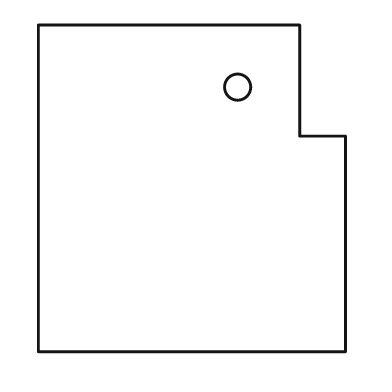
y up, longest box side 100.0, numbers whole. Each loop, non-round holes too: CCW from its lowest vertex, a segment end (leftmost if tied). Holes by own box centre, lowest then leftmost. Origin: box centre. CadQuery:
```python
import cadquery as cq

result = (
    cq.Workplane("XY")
    .moveTo(-47.0, -50.0)
    .lineTo(47.0, -50.0)
    .lineTo(47.0, 16.0)
    .lineTo(33.0, 16.0)
    .lineTo(33.0, 50.0)
    .lineTo(-47.0, 50.0)
    .close()
    .moveTo(14.0, 31.0)
    .circle(4.0)
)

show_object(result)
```